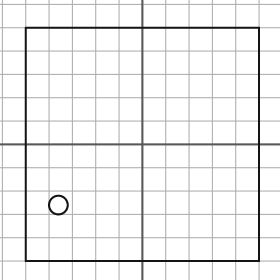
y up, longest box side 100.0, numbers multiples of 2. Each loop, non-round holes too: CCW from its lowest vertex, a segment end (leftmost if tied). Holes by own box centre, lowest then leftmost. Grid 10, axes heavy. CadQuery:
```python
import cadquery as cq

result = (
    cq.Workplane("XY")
    .moveTo(-50.0, -50.0)
    .lineTo(50.0, -50.0)
    .lineTo(50.0, 50.0)
    .lineTo(-50.0, 50.0)
    .close()
    .moveTo(-36.0, -26.0)
    .circle(4.0)
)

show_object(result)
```